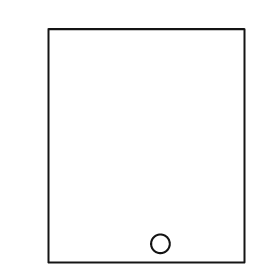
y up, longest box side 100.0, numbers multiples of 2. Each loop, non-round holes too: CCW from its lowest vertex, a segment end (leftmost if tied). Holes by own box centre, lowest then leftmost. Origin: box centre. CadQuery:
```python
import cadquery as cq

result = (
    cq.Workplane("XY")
    .moveTo(-42.0, -50.0)
    .lineTo(42.0, -50.0)
    .lineTo(42.0, 50.0)
    .lineTo(-42.0, 50.0)
    .close()
    .moveTo(6.0, -42.0)
    .circle(4.0)
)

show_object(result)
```